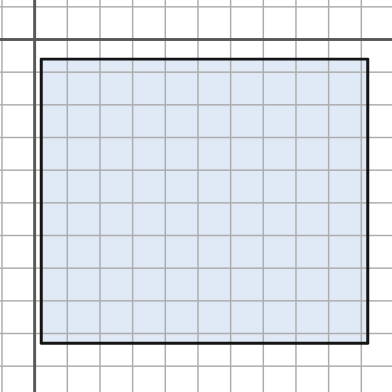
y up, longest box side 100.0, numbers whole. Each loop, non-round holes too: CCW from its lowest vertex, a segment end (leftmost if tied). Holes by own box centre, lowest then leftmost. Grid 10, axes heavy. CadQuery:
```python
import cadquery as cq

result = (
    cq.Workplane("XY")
    .moveTo(2.0, -93.0)
    .lineTo(102.0, -93.0)
    .lineTo(102.0, -6.0)
    .lineTo(2.0, -6.0)
    .close()
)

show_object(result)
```